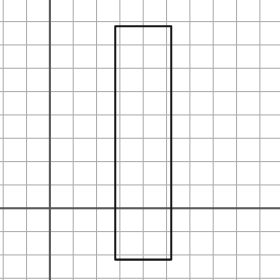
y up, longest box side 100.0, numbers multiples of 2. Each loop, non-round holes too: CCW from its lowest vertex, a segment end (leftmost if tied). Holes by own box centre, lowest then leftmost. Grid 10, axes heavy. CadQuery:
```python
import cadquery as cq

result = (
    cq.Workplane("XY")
    .moveTo(28.0, -22.0)
    .lineTo(52.0, -22.0)
    .lineTo(52.0, 78.0)
    .lineTo(28.0, 78.0)
    .close()
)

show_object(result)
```